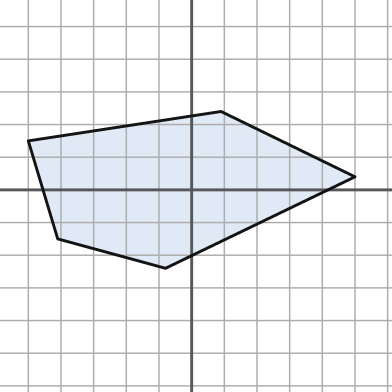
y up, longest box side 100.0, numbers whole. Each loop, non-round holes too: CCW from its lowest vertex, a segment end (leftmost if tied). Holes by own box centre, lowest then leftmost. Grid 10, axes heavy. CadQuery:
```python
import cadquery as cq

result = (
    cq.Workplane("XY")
    .moveTo(-8.0, -24.0)
    .lineTo(50.0, 4.0)
    .lineTo(9.0, 24.0)
    .lineTo(-50.0, 15.0)
    .lineTo(-41.0, -15.0)
    .close()
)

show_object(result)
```